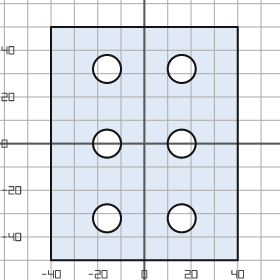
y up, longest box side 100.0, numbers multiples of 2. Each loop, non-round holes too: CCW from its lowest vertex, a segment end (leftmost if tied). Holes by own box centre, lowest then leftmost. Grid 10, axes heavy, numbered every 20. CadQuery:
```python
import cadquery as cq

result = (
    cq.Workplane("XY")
    .moveTo(-40.0, -50.0)
    .lineTo(40.0, -50.0)
    .lineTo(40.0, 50.0)
    .lineTo(-40.0, 50.0)
    .close()
    .moveTo(-16.0, -32.0)
    .circle(6.0)
    .moveTo(16.0, -32.0)
    .circle(6.0)
    .moveTo(-16.0, 0.0)
    .circle(6.0)
    .moveTo(16.0, 0.0)
    .circle(6.0)
    .moveTo(-16.0, 32.0)
    .circle(6.0)
    .moveTo(16.0, 32.0)
    .circle(6.0)
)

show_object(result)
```